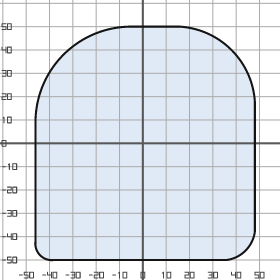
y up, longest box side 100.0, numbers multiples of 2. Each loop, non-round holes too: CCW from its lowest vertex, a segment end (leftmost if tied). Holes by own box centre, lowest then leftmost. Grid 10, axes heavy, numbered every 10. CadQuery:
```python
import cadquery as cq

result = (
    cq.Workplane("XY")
    .moveTo(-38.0, -50.0)
    .lineTo(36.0, -50.0)
    .threePointArc((44.0, -46.0), (48.0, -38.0))
    .lineTo(48.0, 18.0)
    .threePointArc((38.0, 40.0), (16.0, 50.0))
    .lineTo(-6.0, 50.0)
    .threePointArc((-34.0, 38.0), (-46.0, 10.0))
    .lineTo(-46.0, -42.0)
    .threePointArc((-44.0, -48.0), (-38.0, -50.0))
    .close()
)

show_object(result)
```